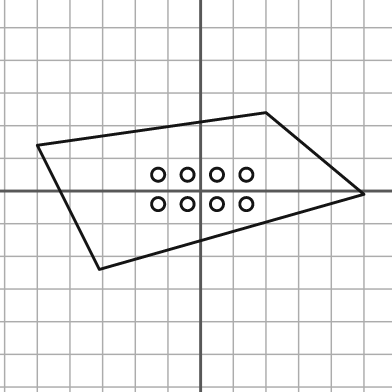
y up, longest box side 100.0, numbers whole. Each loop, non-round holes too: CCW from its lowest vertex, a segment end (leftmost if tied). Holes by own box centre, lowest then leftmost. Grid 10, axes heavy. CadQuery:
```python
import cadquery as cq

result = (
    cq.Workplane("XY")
    .moveTo(-31.0, -24.0)
    .lineTo(50.0, -1.0)
    .lineTo(20.0, 24.0)
    .lineTo(-50.0, 14.0)
    .close()
    .moveTo(-13.0, -4.0)
    .circle(2.0)
    .moveTo(-4.0, -4.0)
    .circle(2.0)
    .moveTo(5.0, -4.0)
    .circle(2.0)
    .moveTo(14.0, -4.0)
    .circle(2.0)
    .moveTo(-13.0, 5.0)
    .circle(2.0)
    .moveTo(-4.0, 5.0)
    .circle(2.0)
    .moveTo(5.0, 5.0)
    .circle(2.0)
    .moveTo(14.0, 5.0)
    .circle(2.0)
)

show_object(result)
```